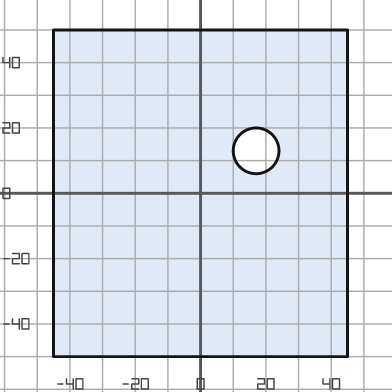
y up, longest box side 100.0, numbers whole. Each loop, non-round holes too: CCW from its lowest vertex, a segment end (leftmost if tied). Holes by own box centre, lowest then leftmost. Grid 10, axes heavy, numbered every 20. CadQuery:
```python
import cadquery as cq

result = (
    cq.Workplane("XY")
    .moveTo(-45.0, -50.0)
    .lineTo(45.0, -50.0)
    .lineTo(45.0, 50.0)
    .lineTo(-45.0, 50.0)
    .close()
    .moveTo(17.0, 13.0)
    .circle(7.0)
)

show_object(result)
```